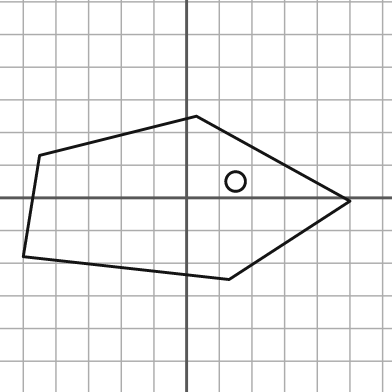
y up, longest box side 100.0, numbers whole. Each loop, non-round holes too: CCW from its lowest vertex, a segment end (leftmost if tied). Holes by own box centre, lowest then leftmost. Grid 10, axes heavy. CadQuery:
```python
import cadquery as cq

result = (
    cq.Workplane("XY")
    .moveTo(13.0, -25.0)
    .lineTo(50.0, -1.0)
    .lineTo(3.0, 25.0)
    .lineTo(-45.0, 13.0)
    .lineTo(-50.0, -18.0)
    .close()
    .moveTo(15.0, 5.0)
    .circle(3.0)
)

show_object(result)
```